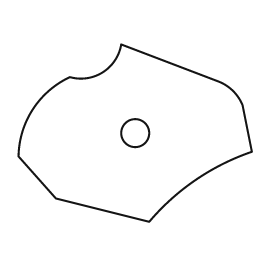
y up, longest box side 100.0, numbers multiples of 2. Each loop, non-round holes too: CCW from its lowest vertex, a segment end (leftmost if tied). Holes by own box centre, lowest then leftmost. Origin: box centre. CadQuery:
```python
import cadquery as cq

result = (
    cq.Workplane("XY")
    .moveTo(6.0, -38.0)
    .threePointArc((26.0, -20.0), (50.0, -8.0))
    .lineTo(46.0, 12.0)
    .threePointArc((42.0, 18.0), (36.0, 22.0))
    .lineTo(-6.0, 38.0)
    .threePointArc((-14.0, 26.0), (-28.0, 24.0))
    .threePointArc((-44.0, 10.0), (-50.0, -10.0))
    .lineTo(-34.0, -28.0)
    .close()
    .moveTo(0.0, 0.0)
    .circle(6.0)
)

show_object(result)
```